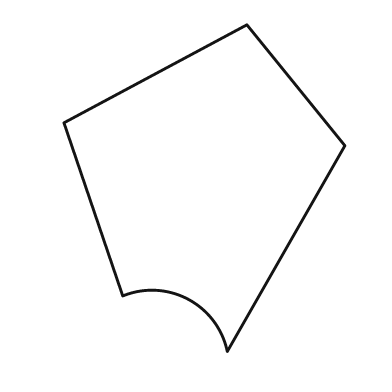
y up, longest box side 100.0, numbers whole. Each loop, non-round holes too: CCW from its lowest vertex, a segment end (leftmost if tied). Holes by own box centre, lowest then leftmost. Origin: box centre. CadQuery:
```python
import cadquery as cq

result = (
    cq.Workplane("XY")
    .moveTo(7.0, -50.0)
    .lineTo(43.0, 13.0)
    .lineTo(13.0, 50.0)
    .lineTo(-43.0, 20.0)
    .lineTo(-25.0, -33.0)
    .threePointArc((-5.0, -34.0), (7.0, -50.0))
    .close()
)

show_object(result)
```